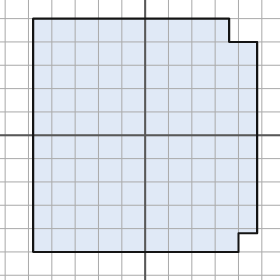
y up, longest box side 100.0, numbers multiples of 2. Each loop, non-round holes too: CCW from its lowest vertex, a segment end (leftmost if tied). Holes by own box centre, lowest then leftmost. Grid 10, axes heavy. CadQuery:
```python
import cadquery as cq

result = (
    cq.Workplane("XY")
    .moveTo(-48.0, -50.0)
    .lineTo(40.0, -50.0)
    .lineTo(40.0, -42.0)
    .lineTo(48.0, -42.0)
    .lineTo(48.0, 40.0)
    .lineTo(36.0, 40.0)
    .lineTo(36.0, 50.0)
    .lineTo(-48.0, 50.0)
    .close()
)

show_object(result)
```